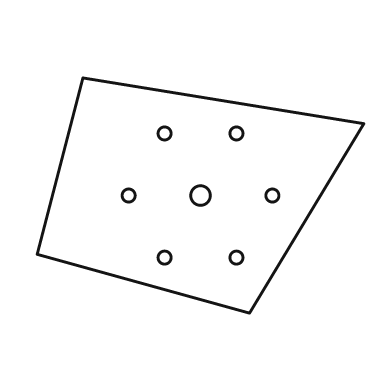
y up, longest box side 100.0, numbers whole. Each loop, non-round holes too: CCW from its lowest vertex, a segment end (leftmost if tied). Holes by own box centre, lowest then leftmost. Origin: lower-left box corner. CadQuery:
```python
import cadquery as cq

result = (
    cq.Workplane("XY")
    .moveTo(65.0, 0.0)
    .lineTo(100.0, 58.0)
    .lineTo(14.0, 72.0)
    .lineTo(0.0, 18.0)
    .close()
    .moveTo(39.0, 17.0)
    .circle(2.0)
    .moveTo(61.0, 17.0)
    .circle(2.0)
    .moveTo(28.0, 36.0)
    .circle(2.0)
    .moveTo(50.0, 36.0)
    .circle(3.0)
    .moveTo(72.0, 36.0)
    .circle(2.0)
    .moveTo(39.0, 55.0)
    .circle(2.0)
    .moveTo(61.0, 55.0)
    .circle(2.0)
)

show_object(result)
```